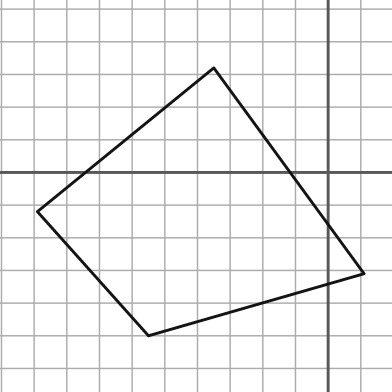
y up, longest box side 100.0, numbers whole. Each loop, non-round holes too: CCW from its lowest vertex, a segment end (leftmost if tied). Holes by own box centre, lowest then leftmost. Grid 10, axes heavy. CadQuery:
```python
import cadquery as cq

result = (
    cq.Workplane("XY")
    .moveTo(-55.0, -50.0)
    .lineTo(11.0, -31.0)
    .lineTo(-35.0, 32.0)
    .lineTo(-89.0, -12.0)
    .close()
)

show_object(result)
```